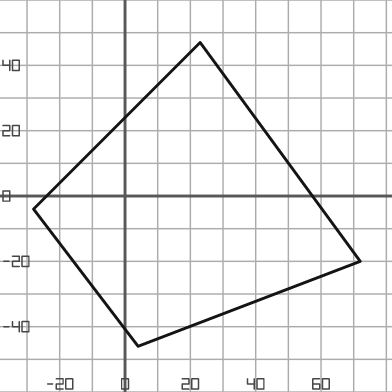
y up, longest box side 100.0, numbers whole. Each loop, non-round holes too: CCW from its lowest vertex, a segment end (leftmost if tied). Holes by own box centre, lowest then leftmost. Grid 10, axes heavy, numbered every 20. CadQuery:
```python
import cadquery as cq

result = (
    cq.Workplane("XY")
    .moveTo(4.0, -46.0)
    .lineTo(72.0, -20.0)
    .lineTo(23.0, 47.0)
    .lineTo(-28.0, -4.0)
    .close()
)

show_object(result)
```